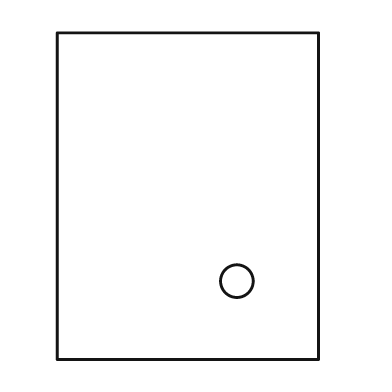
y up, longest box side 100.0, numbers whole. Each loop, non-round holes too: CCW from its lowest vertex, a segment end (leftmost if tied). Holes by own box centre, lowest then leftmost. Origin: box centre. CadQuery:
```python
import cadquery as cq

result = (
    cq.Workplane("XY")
    .moveTo(-40.0, -50.0)
    .lineTo(40.0, -50.0)
    .lineTo(40.0, 50.0)
    .lineTo(-40.0, 50.0)
    .close()
    .moveTo(15.0, -26.0)
    .circle(5.0)
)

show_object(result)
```